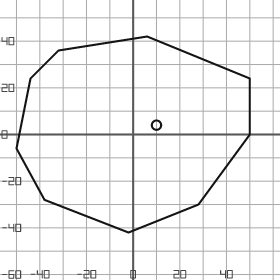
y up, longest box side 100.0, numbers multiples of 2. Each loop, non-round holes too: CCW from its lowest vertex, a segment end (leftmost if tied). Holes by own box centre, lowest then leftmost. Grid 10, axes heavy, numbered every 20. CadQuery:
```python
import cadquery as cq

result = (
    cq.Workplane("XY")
    .moveTo(-2.0, -42.0)
    .lineTo(28.0, -30.0)
    .lineTo(50.0, 0.0)
    .lineTo(50.0, 24.0)
    .lineTo(6.0, 42.0)
    .lineTo(-32.0, 36.0)
    .lineTo(-44.0, 24.0)
    .lineTo(-50.0, -6.0)
    .lineTo(-38.0, -28.0)
    .close()
    .moveTo(10.0, 4.0)
    .circle(2.0)
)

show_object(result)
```